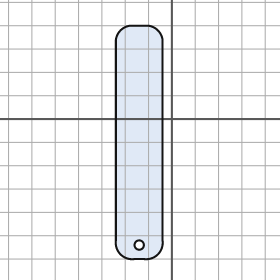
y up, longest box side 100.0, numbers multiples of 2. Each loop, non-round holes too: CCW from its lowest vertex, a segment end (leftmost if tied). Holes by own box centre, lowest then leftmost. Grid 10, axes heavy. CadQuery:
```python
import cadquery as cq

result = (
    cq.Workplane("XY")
    .moveTo(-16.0, -60.0)
    .lineTo(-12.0, -60.0)
    .threePointArc((-6.0, -58.0), (-4.0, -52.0))
    .lineTo(-4.0, 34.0)
    .threePointArc((-6.0, 38.0), (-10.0, 40.0))
    .lineTo(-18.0, 40.0)
    .threePointArc((-22.0, 38.0), (-24.0, 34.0))
    .lineTo(-24.0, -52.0)
    .threePointArc((-22.0, -58.0), (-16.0, -60.0))
    .close()
    .moveTo(-14.0, -54.0)
    .circle(2.0)
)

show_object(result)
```